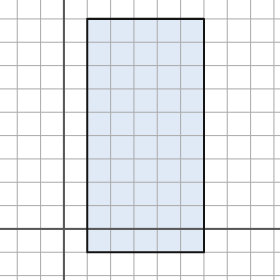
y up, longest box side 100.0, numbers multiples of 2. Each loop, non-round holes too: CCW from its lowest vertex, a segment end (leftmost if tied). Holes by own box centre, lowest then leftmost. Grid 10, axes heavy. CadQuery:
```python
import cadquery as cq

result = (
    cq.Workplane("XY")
    .moveTo(10.0, -10.0)
    .lineTo(60.0, -10.0)
    .lineTo(60.0, 90.0)
    .lineTo(10.0, 90.0)
    .close()
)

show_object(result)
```